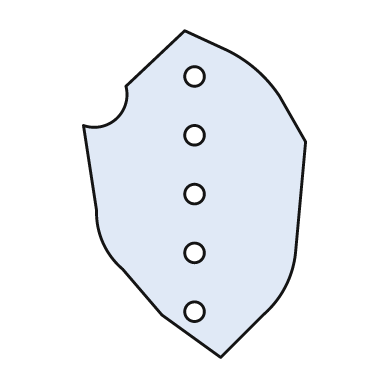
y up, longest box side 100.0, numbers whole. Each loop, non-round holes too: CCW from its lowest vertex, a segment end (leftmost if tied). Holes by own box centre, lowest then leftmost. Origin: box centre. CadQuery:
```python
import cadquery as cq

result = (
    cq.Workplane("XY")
    .moveTo(8.0, -50.0)
    .lineTo(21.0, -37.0)
    .threePointArc((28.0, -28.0), (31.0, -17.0))
    .lineTo(34.0, 16.0)
    .lineTo(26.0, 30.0)
    .threePointArc((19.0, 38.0), (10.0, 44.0))
    .lineTo(-3.0, 50.0)
    .lineTo(-21.0, 33.0)
    .threePointArc((-24.0, 23.0), (-34.0, 21.0))
    .lineTo(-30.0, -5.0)
    .threePointArc((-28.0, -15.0), (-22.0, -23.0))
    .lineTo(-10.0, -37.0)
    .close()
    .moveTo(0.0, -36.0)
    .circle(3.0)
    .moveTo(0.0, -18.0)
    .circle(3.0)
    .moveTo(0.0, 0.0)
    .circle(3.0)
    .moveTo(0.0, 18.0)
    .circle(3.0)
    .moveTo(0.0, 36.0)
    .circle(3.0)
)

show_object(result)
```